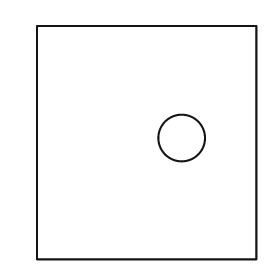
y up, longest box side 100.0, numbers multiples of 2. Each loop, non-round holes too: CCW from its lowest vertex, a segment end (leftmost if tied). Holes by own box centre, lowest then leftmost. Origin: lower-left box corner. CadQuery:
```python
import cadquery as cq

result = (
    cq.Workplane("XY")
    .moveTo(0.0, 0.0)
    .lineTo(94.0, 0.0)
    .lineTo(94.0, 100.0)
    .lineTo(0.0, 100.0)
    .close()
    .moveTo(62.0, 52.0)
    .circle(10.0)
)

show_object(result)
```